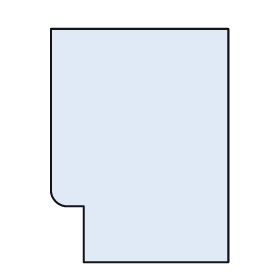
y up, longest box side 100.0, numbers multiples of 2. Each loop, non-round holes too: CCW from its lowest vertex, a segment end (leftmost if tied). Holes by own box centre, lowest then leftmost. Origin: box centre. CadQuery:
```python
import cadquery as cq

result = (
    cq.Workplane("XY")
    .moveTo(-24.0, -50.0)
    .lineTo(38.0, -50.0)
    .lineTo(38.0, 50.0)
    .lineTo(-38.0, 50.0)
    .lineTo(-38.0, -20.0)
    .threePointArc((-36.0, -24.0), (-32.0, -26.0))
    .lineTo(-24.0, -26.0)
    .close()
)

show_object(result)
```